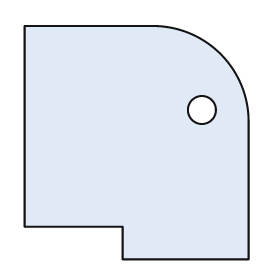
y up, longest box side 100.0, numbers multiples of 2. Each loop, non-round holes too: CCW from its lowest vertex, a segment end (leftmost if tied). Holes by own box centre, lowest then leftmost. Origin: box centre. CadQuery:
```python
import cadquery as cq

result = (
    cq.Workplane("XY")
    .moveTo(-6.0, -50.0)
    .lineTo(48.0, -50.0)
    .lineTo(48.0, 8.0)
    .threePointArc((36.0, 38.0), (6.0, 50.0))
    .lineTo(-48.0, 50.0)
    .lineTo(-48.0, -36.0)
    .lineTo(-6.0, -36.0)
    .close()
    .moveTo(28.0, 14.0)
    .circle(6.0)
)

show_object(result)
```